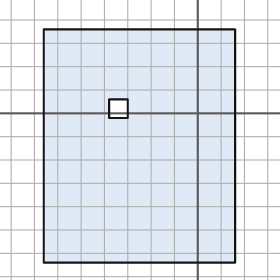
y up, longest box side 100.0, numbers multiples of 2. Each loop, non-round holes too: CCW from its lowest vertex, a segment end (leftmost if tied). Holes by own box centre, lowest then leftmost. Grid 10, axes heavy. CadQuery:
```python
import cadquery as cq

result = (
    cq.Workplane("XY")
    .moveTo(-66.0, -64.0)
    .lineTo(16.0, -64.0)
    .lineTo(16.0, 36.0)
    .lineTo(-66.0, 36.0)
    .close()
    .moveTo(-38.0, -2.0)
    .lineTo(-30.0, -2.0)
    .lineTo(-30.0, 6.0)
    .lineTo(-38.0, 6.0)
    .close()
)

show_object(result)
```